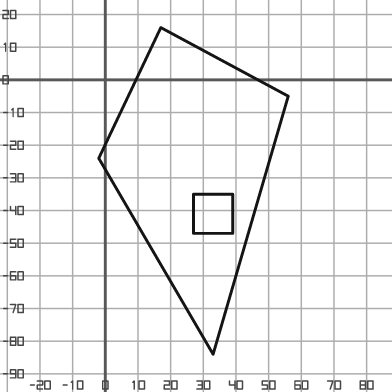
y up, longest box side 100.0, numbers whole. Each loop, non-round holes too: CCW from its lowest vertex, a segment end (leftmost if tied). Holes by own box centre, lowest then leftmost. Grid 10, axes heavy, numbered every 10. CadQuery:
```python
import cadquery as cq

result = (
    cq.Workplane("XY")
    .moveTo(33.0, -84.0)
    .lineTo(56.0, -5.0)
    .lineTo(17.0, 16.0)
    .lineTo(-2.0, -24.0)
    .close()
    .moveTo(27.0, -47.0)
    .lineTo(39.0, -47.0)
    .lineTo(39.0, -35.0)
    .lineTo(27.0, -35.0)
    .close()
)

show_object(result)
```